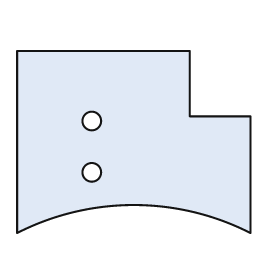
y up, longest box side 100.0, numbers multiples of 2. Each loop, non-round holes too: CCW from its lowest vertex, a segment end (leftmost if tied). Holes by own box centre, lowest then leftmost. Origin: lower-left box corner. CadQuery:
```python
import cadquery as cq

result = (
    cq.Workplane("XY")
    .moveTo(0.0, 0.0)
    .threePointArc((50.0, 12.0), (100.0, 0.0))
    .lineTo(100.0, 50.0)
    .lineTo(74.0, 50.0)
    .lineTo(74.0, 78.0)
    .lineTo(0.0, 78.0)
    .close()
    .moveTo(32.0, 26.0)
    .circle(4.0)
    .moveTo(32.0, 48.0)
    .circle(4.0)
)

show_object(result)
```